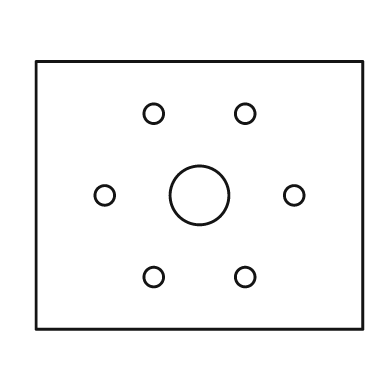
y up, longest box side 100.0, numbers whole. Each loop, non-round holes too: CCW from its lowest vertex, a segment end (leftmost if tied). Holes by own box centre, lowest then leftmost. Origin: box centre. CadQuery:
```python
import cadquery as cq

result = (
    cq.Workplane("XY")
    .moveTo(-50.0, -41.0)
    .lineTo(50.0, -41.0)
    .lineTo(50.0, 41.0)
    .lineTo(-50.0, 41.0)
    .close()
    .moveTo(-14.0, -25.0)
    .circle(3.0)
    .moveTo(14.0, -25.0)
    .circle(3.0)
    .moveTo(-29.0, 0.0)
    .circle(3.0)
    .moveTo(0.0, 0.0)
    .circle(9.0)
    .moveTo(29.0, 0.0)
    .circle(3.0)
    .moveTo(-14.0, 25.0)
    .circle(3.0)
    .moveTo(14.0, 25.0)
    .circle(3.0)
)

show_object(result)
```